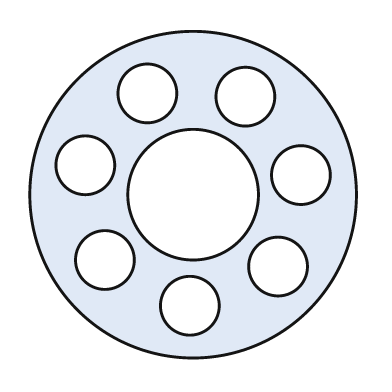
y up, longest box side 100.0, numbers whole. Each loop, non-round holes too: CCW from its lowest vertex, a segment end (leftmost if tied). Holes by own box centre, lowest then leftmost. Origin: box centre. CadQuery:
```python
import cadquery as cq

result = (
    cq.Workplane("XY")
    .moveTo(0.0, 0.0)
    .circle(50.0)
    .moveTo(-1.0, -34.0)
    .circle(9.0)
    .moveTo(26.0, -22.0)
    .circle(9.0)
    .moveTo(-27.0, -20.0)
    .circle(9.0)
    .moveTo(0.0, 0.0)
    .circle(20.0)
    .moveTo(33.0, 6.0)
    .circle(9.0)
    .moveTo(-33.0, 9.0)
    .circle(9.0)
    .moveTo(16.0, 30.0)
    .circle(9.0)
    .moveTo(-14.0, 31.0)
    .circle(9.0)
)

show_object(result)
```